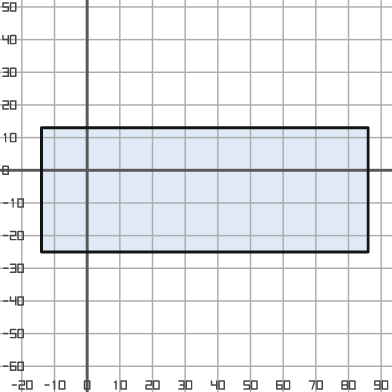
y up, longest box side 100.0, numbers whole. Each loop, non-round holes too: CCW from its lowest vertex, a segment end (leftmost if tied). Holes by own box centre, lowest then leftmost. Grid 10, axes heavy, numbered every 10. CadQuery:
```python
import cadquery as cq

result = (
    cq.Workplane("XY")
    .moveTo(-14.0, -25.0)
    .lineTo(86.0, -25.0)
    .lineTo(86.0, 13.0)
    .lineTo(-14.0, 13.0)
    .close()
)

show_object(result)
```